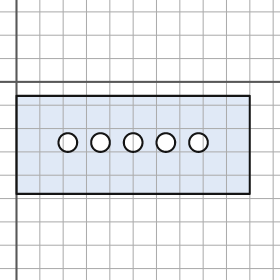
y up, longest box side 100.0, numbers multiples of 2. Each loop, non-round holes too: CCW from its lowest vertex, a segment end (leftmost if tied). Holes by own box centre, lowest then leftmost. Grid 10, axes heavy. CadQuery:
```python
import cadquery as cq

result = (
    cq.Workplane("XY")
    .moveTo(0.0, -48.0)
    .lineTo(100.0, -48.0)
    .lineTo(100.0, -6.0)
    .lineTo(0.0, -6.0)
    .close()
    .moveTo(22.0, -26.0)
    .circle(4.0)
    .moveTo(36.0, -26.0)
    .circle(4.0)
    .moveTo(50.0, -26.0)
    .circle(4.0)
    .moveTo(64.0, -26.0)
    .circle(4.0)
    .moveTo(78.0, -26.0)
    .circle(4.0)
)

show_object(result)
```